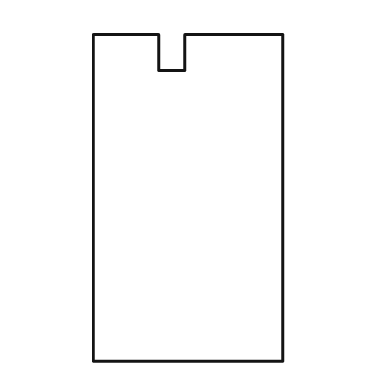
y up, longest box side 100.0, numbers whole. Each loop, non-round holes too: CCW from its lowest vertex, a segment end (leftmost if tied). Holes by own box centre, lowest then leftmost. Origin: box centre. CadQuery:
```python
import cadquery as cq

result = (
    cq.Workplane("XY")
    .moveTo(-29.0, -50.0)
    .lineTo(29.0, -50.0)
    .lineTo(29.0, 50.0)
    .lineTo(-1.0, 50.0)
    .lineTo(-1.0, 39.0)
    .lineTo(-9.0, 39.0)
    .lineTo(-9.0, 50.0)
    .lineTo(-29.0, 50.0)
    .close()
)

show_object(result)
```